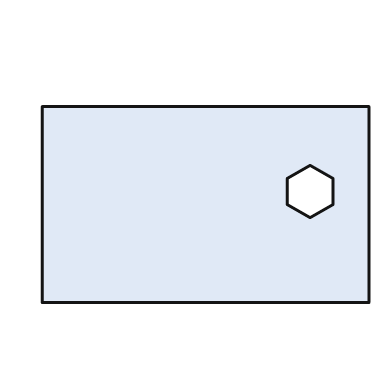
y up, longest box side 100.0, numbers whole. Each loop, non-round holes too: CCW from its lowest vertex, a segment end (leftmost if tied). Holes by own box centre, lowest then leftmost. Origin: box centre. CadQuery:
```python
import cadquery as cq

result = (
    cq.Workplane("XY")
    .moveTo(-50.0, -30.0)
    .lineTo(50.0, -30.0)
    .lineTo(50.0, 30.0)
    .lineTo(-50.0, 30.0)
    .close()
    .moveTo(32.0, -4.0)
    .lineTo(39.0, 0.0)
    .lineTo(39.0, 8.0)
    .lineTo(32.0, 12.0)
    .lineTo(25.0, 8.0)
    .lineTo(25.0, 0.0)
    .close()
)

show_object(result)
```